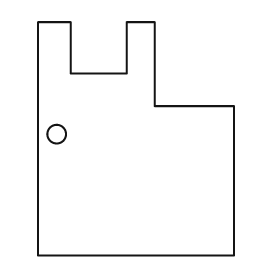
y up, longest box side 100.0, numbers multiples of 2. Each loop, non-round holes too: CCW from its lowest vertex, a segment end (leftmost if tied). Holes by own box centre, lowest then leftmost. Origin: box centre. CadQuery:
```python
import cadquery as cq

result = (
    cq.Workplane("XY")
    .moveTo(-42.0, -50.0)
    .lineTo(42.0, -50.0)
    .lineTo(42.0, 14.0)
    .lineTo(8.0, 14.0)
    .lineTo(8.0, 50.0)
    .lineTo(-4.0, 50.0)
    .lineTo(-4.0, 28.0)
    .lineTo(-28.0, 28.0)
    .lineTo(-28.0, 50.0)
    .lineTo(-42.0, 50.0)
    .close()
    .moveTo(-34.0, 2.0)
    .circle(4.0)
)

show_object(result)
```